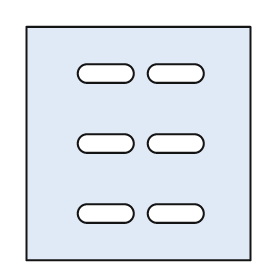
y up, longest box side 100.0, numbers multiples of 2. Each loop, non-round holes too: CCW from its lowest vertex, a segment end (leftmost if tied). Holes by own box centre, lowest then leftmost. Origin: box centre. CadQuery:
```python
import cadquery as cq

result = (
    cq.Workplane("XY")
    .moveTo(-48.0, -50.0)
    .lineTo(48.0, -50.0)
    .lineTo(48.0, 50.0)
    .lineTo(-48.0, 50.0)
    .close()
    .moveTo(-22.0, -34.0)
    .lineTo(-6.0, -34.0)
    .threePointArc((-2.0, -30.0), (-6.0, -26.0))
    .lineTo(-22.0, -26.0)
    .threePointArc((-26.0, -30.0), (-22.0, -34.0))
    .close()
    .moveTo(8.0, -34.0)
    .lineTo(24.0, -34.0)
    .threePointArc((28.0, -30.0), (24.0, -26.0))
    .lineTo(8.0, -26.0)
    .threePointArc((4.0, -30.0), (8.0, -34.0))
    .close()
    .moveTo(-22.0, -4.0)
    .lineTo(-6.0, -4.0)
    .threePointArc((-2.0, 0.0), (-6.0, 4.0))
    .lineTo(-22.0, 4.0)
    .threePointArc((-26.0, 0.0), (-22.0, -4.0))
    .close()
    .moveTo(8.0, -4.0)
    .lineTo(24.0, -4.0)
    .threePointArc((28.0, 0.0), (24.0, 4.0))
    .lineTo(8.0, 4.0)
    .threePointArc((4.0, 0.0), (8.0, -4.0))
    .close()
    .moveTo(-22.0, 26.0)
    .lineTo(-6.0, 26.0)
    .threePointArc((-2.0, 30.0), (-6.0, 34.0))
    .lineTo(-22.0, 34.0)
    .threePointArc((-26.0, 30.0), (-22.0, 26.0))
    .close()
    .moveTo(8.0, 26.0)
    .lineTo(24.0, 26.0)
    .threePointArc((28.0, 30.0), (24.0, 34.0))
    .lineTo(8.0, 34.0)
    .threePointArc((4.0, 30.0), (8.0, 26.0))
    .close()
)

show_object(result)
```